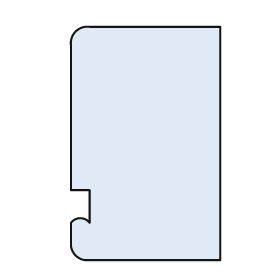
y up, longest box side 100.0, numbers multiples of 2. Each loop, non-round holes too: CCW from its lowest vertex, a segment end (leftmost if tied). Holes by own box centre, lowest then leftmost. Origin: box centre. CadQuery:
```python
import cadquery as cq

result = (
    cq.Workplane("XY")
    .moveTo(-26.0, -50.0)
    .lineTo(32.0, -50.0)
    .lineTo(32.0, 50.0)
    .lineTo(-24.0, 50.0)
    .threePointArc((-30.0, 48.0), (-32.0, 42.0))
    .lineTo(-32.0, -20.0)
    .lineTo(-24.0, -20.0)
    .lineTo(-24.0, -34.0)
    .threePointArc((-28.0, -32.0), (-32.0, -34.0))
    .lineTo(-32.0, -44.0)
    .threePointArc((-30.0, -48.0), (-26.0, -50.0))
    .close()
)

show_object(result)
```